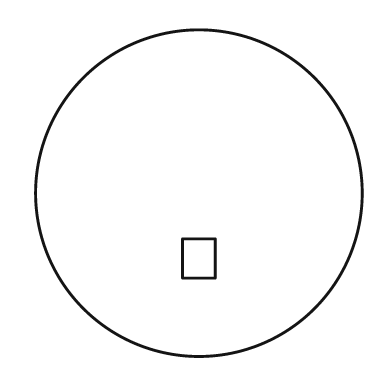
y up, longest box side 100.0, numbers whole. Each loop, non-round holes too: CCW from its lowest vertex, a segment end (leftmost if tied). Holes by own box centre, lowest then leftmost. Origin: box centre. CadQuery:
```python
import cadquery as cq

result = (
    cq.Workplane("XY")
    .moveTo(0.0, 0.0)
    .circle(50.0)
    .moveTo(-5.0, -26.0)
    .lineTo(5.0, -26.0)
    .lineTo(5.0, -14.0)
    .lineTo(-5.0, -14.0)
    .close()
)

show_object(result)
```